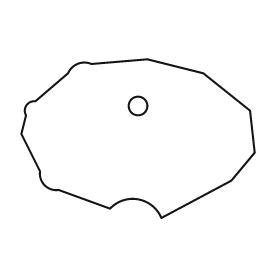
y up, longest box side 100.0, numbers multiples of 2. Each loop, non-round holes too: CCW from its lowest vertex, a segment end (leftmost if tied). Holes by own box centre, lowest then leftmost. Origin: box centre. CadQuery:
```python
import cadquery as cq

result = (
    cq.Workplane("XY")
    .moveTo(10.0, -34.0)
    .lineTo(40.0, -18.0)
    .lineTo(50.0, -6.0)
    .lineTo(48.0, 12.0)
    .lineTo(28.0, 28.0)
    .lineTo(4.0, 34.0)
    .lineTo(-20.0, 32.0)
    .threePointArc((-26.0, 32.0), (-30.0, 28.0))
    .lineTo(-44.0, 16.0)
    .threePointArc((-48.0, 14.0), (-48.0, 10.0))
    .lineTo(-50.0, 2.0)
    .lineTo(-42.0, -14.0)
    .threePointArc((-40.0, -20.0), (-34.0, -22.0))
    .lineTo(-12.0, -30.0)
    .threePointArc((0.0, -26.0), (10.0, -34.0))
    .close()
    .moveTo(0.0, 14.0)
    .circle(4.0)
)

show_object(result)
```